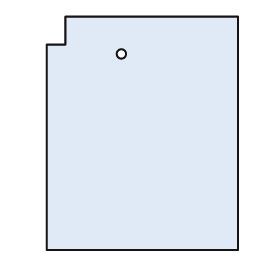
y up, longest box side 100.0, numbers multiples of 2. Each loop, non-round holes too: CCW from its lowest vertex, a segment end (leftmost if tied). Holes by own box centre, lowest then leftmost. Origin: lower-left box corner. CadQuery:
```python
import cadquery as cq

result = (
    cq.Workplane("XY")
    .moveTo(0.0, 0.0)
    .lineTo(82.0, 0.0)
    .lineTo(82.0, 100.0)
    .lineTo(8.0, 100.0)
    .lineTo(8.0, 88.0)
    .lineTo(0.0, 88.0)
    .close()
    .moveTo(32.0, 84.0)
    .circle(2.0)
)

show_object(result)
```